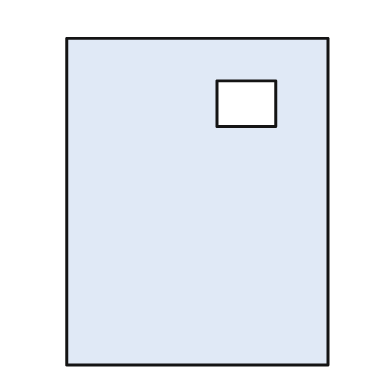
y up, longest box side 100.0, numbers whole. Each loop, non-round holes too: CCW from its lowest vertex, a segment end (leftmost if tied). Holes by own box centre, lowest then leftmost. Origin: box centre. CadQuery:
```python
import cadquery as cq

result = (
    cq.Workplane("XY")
    .moveTo(-40.0, -50.0)
    .lineTo(40.0, -50.0)
    .lineTo(40.0, 50.0)
    .lineTo(-40.0, 50.0)
    .close()
    .moveTo(6.0, 23.0)
    .lineTo(24.0, 23.0)
    .lineTo(24.0, 37.0)
    .lineTo(6.0, 37.0)
    .close()
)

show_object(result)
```